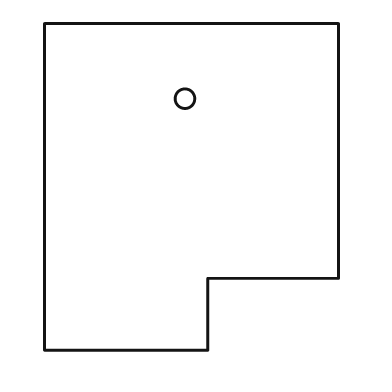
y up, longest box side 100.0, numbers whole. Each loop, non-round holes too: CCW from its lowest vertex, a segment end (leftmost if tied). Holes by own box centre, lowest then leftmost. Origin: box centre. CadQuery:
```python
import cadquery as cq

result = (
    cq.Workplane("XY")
    .moveTo(-45.0, -50.0)
    .lineTo(5.0, -50.0)
    .lineTo(5.0, -28.0)
    .lineTo(45.0, -28.0)
    .lineTo(45.0, 50.0)
    .lineTo(-45.0, 50.0)
    .close()
    .moveTo(-2.0, 27.0)
    .circle(3.0)
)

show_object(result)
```